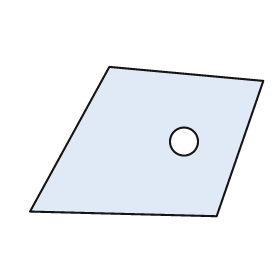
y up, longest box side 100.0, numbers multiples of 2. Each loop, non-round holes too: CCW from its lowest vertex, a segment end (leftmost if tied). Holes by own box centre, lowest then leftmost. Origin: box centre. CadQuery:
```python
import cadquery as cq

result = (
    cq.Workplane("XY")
    .moveTo(30.0, -32.0)
    .lineTo(50.0, 26.0)
    .lineTo(-16.0, 32.0)
    .lineTo(-50.0, -30.0)
    .close()
    .moveTo(16.0, 0.0)
    .circle(6.0)
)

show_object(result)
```